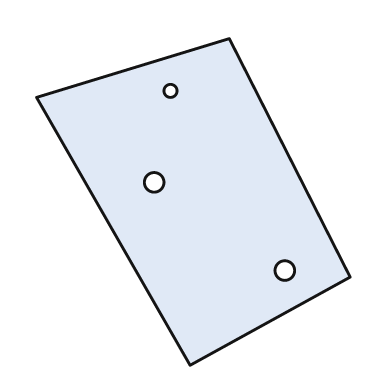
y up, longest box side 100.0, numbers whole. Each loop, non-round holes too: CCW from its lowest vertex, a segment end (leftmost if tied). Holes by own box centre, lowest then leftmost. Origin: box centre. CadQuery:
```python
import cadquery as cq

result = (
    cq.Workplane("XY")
    .moveTo(-1.0, -50.0)
    .lineTo(48.0, -23.0)
    .lineTo(11.0, 50.0)
    .lineTo(-48.0, 32.0)
    .close()
    .moveTo(28.0, -21.0)
    .circle(3.0)
    .moveTo(-12.0, 6.0)
    .circle(3.0)
    .moveTo(-7.0, 34.0)
    .circle(2.0)
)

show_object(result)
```